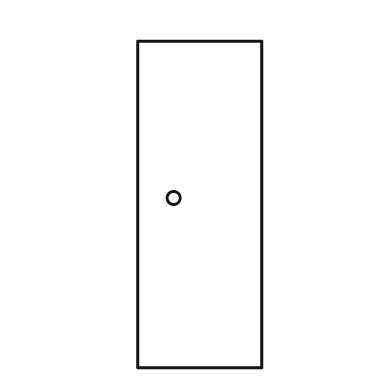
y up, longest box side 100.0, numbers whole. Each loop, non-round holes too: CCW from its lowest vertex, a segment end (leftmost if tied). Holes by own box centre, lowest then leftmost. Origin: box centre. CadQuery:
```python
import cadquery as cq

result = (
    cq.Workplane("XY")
    .moveTo(-19.0, -50.0)
    .lineTo(19.0, -50.0)
    .lineTo(19.0, 50.0)
    .lineTo(-19.0, 50.0)
    .close()
    .moveTo(-8.0, 2.0)
    .circle(2.0)
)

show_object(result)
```